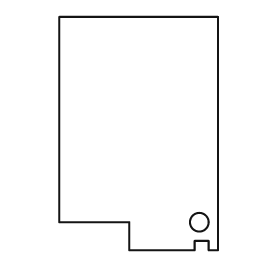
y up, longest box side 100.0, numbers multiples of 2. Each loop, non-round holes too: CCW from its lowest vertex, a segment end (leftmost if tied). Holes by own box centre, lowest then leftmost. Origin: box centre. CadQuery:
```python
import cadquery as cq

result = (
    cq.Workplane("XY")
    .moveTo(-4.0, -50.0)
    .lineTo(24.0, -50.0)
    .lineTo(24.0, -46.0)
    .lineTo(30.0, -46.0)
    .lineTo(30.0, -50.0)
    .lineTo(34.0, -50.0)
    .lineTo(34.0, 50.0)
    .lineTo(-34.0, 50.0)
    .lineTo(-34.0, -38.0)
    .lineTo(-4.0, -38.0)
    .close()
    .moveTo(26.0, -38.0)
    .circle(4.0)
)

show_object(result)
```